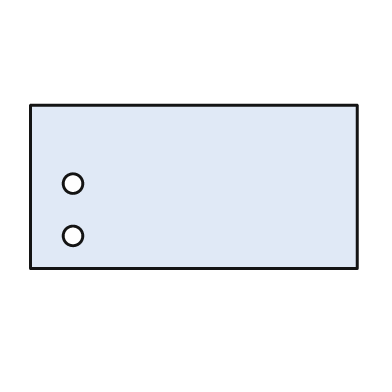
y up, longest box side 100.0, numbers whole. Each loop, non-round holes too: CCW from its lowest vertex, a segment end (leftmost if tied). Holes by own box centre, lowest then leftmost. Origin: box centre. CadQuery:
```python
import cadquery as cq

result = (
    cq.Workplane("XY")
    .moveTo(-50.0, -25.0)
    .lineTo(50.0, -25.0)
    .lineTo(50.0, 25.0)
    .lineTo(-50.0, 25.0)
    .close()
    .moveTo(-37.0, -15.0)
    .circle(3.0)
    .moveTo(-37.0, 1.0)
    .circle(3.0)
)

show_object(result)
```